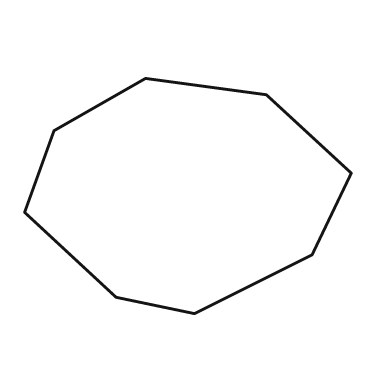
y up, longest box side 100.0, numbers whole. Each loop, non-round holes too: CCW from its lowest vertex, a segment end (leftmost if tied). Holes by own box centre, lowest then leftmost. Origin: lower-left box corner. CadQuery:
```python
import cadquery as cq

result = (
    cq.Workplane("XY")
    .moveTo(52.0, 0.0)
    .lineTo(88.0, 18.0)
    .lineTo(100.0, 43.0)
    .lineTo(74.0, 67.0)
    .lineTo(37.0, 72.0)
    .lineTo(9.0, 56.0)
    .lineTo(0.0, 31.0)
    .lineTo(28.0, 5.0)
    .close()
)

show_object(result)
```